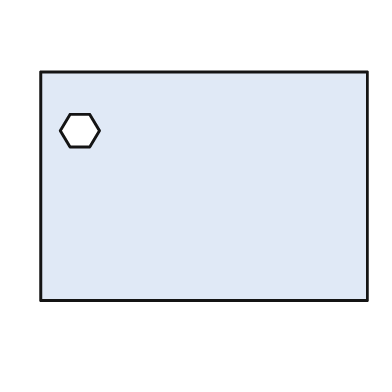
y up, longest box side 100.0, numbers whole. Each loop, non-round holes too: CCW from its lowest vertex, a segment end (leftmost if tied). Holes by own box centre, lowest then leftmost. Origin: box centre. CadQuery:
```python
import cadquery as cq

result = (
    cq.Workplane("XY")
    .moveTo(-50.0, -35.0)
    .lineTo(50.0, -35.0)
    .lineTo(50.0, 35.0)
    .lineTo(-50.0, 35.0)
    .close()
    .moveTo(-41.0, 12.0)
    .lineTo(-35.0, 12.0)
    .lineTo(-32.0, 17.0)
    .lineTo(-35.0, 22.0)
    .lineTo(-41.0, 22.0)
    .lineTo(-44.0, 17.0)
    .close()
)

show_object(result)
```